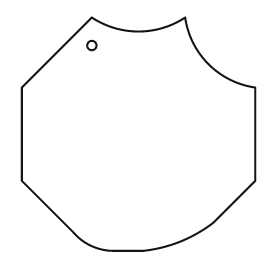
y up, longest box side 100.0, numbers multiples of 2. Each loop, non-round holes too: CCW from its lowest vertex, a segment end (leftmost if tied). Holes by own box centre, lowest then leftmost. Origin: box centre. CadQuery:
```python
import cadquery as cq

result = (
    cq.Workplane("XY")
    .moveTo(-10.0, -50.0)
    .lineTo(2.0, -50.0)
    .threePointArc((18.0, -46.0), (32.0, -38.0))
    .lineTo(50.0, -20.0)
    .lineTo(50.0, 20.0)
    .threePointArc((30.0, 30.0), (20.0, 50.0))
    .threePointArc((0.0, 44.0), (-20.0, 50.0))
    .lineTo(-50.0, 20.0)
    .lineTo(-50.0, -20.0)
    .lineTo(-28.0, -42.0)
    .threePointArc((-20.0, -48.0), (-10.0, -50.0))
    .close()
    .moveTo(-20.0, 38.0)
    .circle(2.0)
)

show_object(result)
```